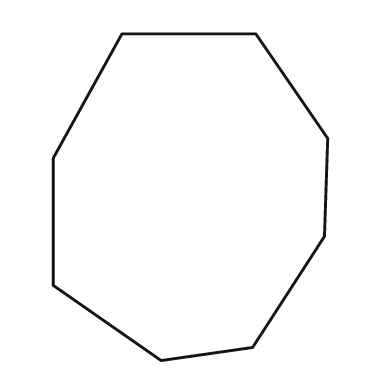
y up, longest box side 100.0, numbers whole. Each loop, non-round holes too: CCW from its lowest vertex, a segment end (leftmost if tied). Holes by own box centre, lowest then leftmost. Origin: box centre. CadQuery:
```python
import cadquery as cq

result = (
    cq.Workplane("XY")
    .moveTo(-9.0, -50.0)
    .lineTo(19.0, -46.0)
    .lineTo(41.0, -12.0)
    .lineTo(42.0, 18.0)
    .lineTo(20.0, 50.0)
    .lineTo(-21.0, 50.0)
    .lineTo(-42.0, 12.0)
    .lineTo(-42.0, -27.0)
    .close()
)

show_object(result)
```